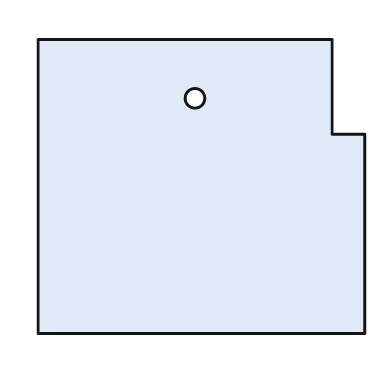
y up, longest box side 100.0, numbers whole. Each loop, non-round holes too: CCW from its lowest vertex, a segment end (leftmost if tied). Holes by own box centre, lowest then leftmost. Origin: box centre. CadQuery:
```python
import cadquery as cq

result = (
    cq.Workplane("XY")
    .moveTo(-50.0, -45.0)
    .lineTo(50.0, -45.0)
    .lineTo(50.0, 16.0)
    .lineTo(40.0, 16.0)
    .lineTo(40.0, 45.0)
    .lineTo(-50.0, 45.0)
    .close()
    .moveTo(-2.0, 27.0)
    .circle(3.0)
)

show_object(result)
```